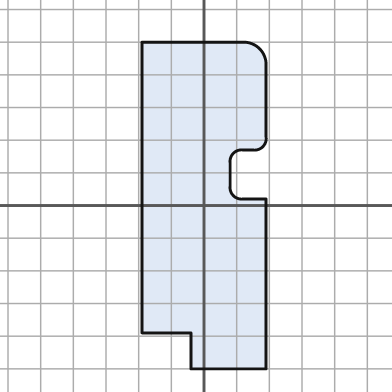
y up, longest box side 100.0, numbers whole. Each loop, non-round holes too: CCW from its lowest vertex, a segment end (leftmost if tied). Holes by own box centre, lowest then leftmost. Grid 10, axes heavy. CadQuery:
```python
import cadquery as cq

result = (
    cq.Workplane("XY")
    .moveTo(-4.0, -50.0)
    .lineTo(19.0, -50.0)
    .lineTo(19.0, 2.0)
    .lineTo(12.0, 2.0)
    .threePointArc((9.0, 3.0), (8.0, 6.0))
    .lineTo(8.0, 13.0)
    .threePointArc((9.0, 16.0), (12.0, 17.0))
    .lineTo(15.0, 17.0)
    .threePointArc((18.0, 18.0), (19.0, 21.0))
    .lineTo(19.0, 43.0)
    .threePointArc((17.0, 48.0), (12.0, 50.0))
    .lineTo(-19.0, 50.0)
    .lineTo(-19.0, -39.0)
    .lineTo(-4.0, -39.0)
    .close()
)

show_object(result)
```